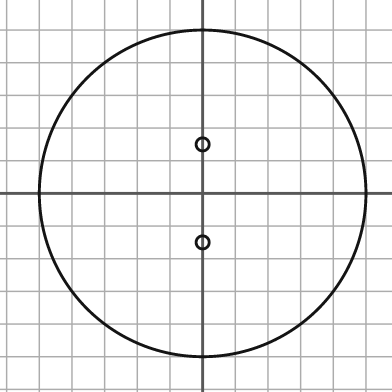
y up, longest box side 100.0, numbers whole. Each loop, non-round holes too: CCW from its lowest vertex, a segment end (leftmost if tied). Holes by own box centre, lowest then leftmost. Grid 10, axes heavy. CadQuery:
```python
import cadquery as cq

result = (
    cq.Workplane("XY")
    .moveTo(0.0, 0.0)
    .circle(50.0)
    .moveTo(0.0, -15.0)
    .circle(2.0)
    .moveTo(0.0, 15.0)
    .circle(2.0)
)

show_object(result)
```